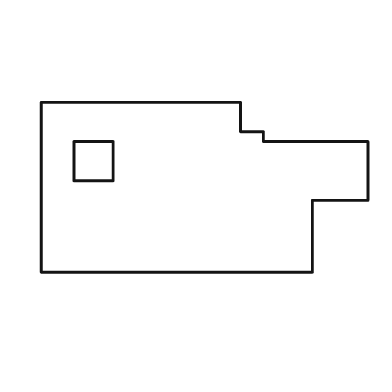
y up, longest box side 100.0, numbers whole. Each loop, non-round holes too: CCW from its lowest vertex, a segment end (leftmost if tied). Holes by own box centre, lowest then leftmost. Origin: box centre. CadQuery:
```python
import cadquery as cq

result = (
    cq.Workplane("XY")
    .moveTo(-50.0, -26.0)
    .lineTo(33.0, -26.0)
    .lineTo(33.0, -4.0)
    .lineTo(50.0, -4.0)
    .lineTo(50.0, 14.0)
    .lineTo(18.0, 14.0)
    .lineTo(18.0, 17.0)
    .lineTo(11.0, 17.0)
    .lineTo(11.0, 26.0)
    .lineTo(-50.0, 26.0)
    .close()
    .moveTo(-40.0, 2.0)
    .lineTo(-28.0, 2.0)
    .lineTo(-28.0, 14.0)
    .lineTo(-40.0, 14.0)
    .close()
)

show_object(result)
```